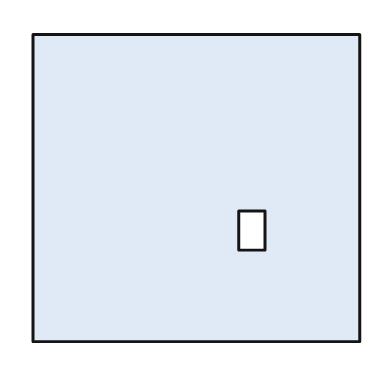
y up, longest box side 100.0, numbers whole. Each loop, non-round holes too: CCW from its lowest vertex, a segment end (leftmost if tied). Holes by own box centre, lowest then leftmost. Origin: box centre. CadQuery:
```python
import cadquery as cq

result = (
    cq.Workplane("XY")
    .moveTo(-50.0, -47.0)
    .lineTo(50.0, -47.0)
    .lineTo(50.0, 47.0)
    .lineTo(-50.0, 47.0)
    .close()
    .moveTo(13.0, -19.0)
    .lineTo(21.0, -19.0)
    .lineTo(21.0, -7.0)
    .lineTo(13.0, -7.0)
    .close()
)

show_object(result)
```